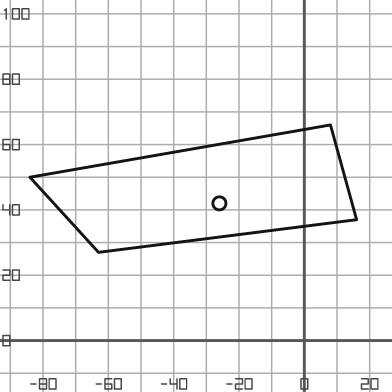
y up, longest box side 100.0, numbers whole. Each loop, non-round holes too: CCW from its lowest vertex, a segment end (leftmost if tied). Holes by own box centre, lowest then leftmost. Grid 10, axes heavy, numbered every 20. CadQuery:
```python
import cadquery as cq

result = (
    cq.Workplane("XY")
    .moveTo(-63.0, 27.0)
    .lineTo(16.0, 37.0)
    .lineTo(8.0, 66.0)
    .lineTo(-84.0, 50.0)
    .close()
    .moveTo(-26.0, 42.0)
    .circle(2.0)
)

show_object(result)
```